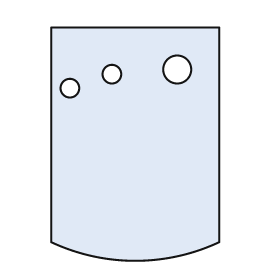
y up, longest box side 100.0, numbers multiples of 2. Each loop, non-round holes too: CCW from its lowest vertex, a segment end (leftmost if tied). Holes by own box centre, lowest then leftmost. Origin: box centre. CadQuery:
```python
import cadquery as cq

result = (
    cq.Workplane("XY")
    .moveTo(-36.0, -42.0)
    .threePointArc((0.0, -50.0), (36.0, -42.0))
    .lineTo(36.0, 50.0)
    .lineTo(-36.0, 50.0)
    .close()
    .moveTo(-28.0, 24.0)
    .circle(4.0)
    .moveTo(-10.0, 30.0)
    .circle(4.0)
    .moveTo(18.0, 32.0)
    .circle(6.0)
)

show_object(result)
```